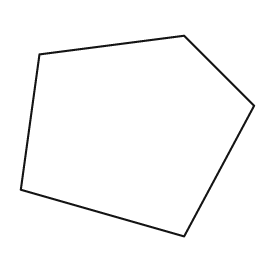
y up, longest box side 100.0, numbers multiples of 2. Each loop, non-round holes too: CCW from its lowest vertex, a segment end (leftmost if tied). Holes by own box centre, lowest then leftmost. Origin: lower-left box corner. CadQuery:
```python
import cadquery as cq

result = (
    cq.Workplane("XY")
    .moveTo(70.0, 0.0)
    .lineTo(100.0, 56.0)
    .lineTo(70.0, 86.0)
    .lineTo(8.0, 78.0)
    .lineTo(0.0, 20.0)
    .close()
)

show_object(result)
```